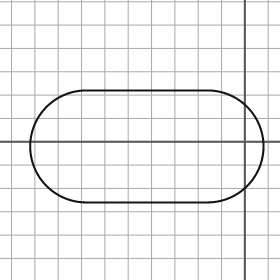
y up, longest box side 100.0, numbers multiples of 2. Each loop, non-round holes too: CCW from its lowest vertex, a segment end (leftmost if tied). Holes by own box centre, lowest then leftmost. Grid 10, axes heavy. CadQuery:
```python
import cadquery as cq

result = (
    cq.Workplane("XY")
    .moveTo(-68.0, -26.0)
    .lineTo(-16.0, -26.0)
    .threePointArc((8.0, -2.0), (-16.0, 22.0))
    .lineTo(-68.0, 22.0)
    .threePointArc((-92.0, -2.0), (-68.0, -26.0))
    .close()
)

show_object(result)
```